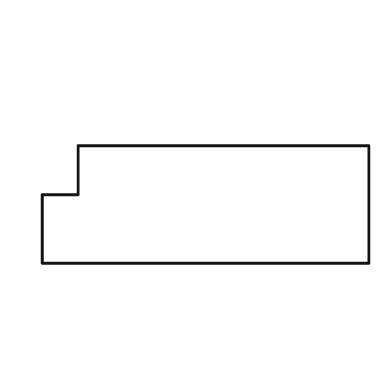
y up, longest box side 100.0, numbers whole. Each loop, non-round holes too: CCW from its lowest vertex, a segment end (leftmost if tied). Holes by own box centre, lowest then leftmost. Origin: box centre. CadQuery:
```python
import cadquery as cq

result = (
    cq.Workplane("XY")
    .moveTo(-50.0, -18.0)
    .lineTo(50.0, -18.0)
    .lineTo(50.0, 18.0)
    .lineTo(-39.0, 18.0)
    .lineTo(-39.0, 3.0)
    .lineTo(-50.0, 3.0)
    .close()
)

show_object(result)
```